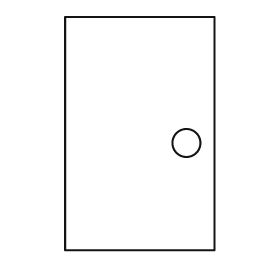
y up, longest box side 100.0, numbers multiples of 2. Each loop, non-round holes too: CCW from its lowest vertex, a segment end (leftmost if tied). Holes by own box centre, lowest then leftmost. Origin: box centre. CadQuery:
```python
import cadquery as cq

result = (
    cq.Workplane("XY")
    .moveTo(-32.0, -50.0)
    .lineTo(32.0, -50.0)
    .lineTo(32.0, 50.0)
    .lineTo(-32.0, 50.0)
    .close()
    .moveTo(20.0, -4.0)
    .circle(6.0)
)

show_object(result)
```